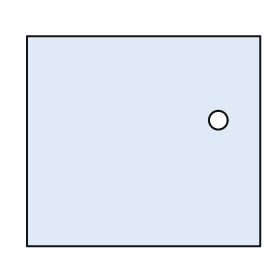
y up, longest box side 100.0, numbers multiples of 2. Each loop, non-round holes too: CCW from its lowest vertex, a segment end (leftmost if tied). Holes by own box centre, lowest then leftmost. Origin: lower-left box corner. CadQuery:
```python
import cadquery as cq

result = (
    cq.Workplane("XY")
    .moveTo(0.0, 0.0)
    .lineTo(100.0, 0.0)
    .lineTo(100.0, 90.0)
    .lineTo(0.0, 90.0)
    .close()
    .moveTo(82.0, 54.0)
    .circle(4.0)
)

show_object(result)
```